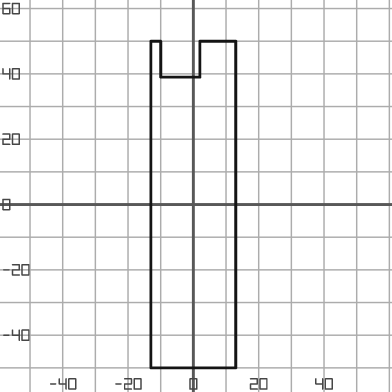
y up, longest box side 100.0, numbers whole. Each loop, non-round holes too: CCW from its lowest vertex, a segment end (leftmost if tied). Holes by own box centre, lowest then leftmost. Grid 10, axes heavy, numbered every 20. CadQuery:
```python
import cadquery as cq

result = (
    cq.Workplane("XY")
    .moveTo(-13.0, -50.0)
    .lineTo(13.0, -50.0)
    .lineTo(13.0, 50.0)
    .lineTo(2.0, 50.0)
    .lineTo(2.0, 39.0)
    .lineTo(-10.0, 39.0)
    .lineTo(-10.0, 50.0)
    .lineTo(-13.0, 50.0)
    .close()
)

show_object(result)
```